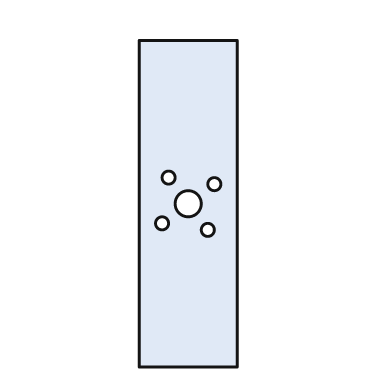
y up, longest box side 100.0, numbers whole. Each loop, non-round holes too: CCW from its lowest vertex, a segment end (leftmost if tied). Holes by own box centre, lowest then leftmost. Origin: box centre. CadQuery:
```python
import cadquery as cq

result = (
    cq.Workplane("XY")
    .moveTo(-15.0, -50.0)
    .lineTo(15.0, -50.0)
    .lineTo(15.0, 50.0)
    .lineTo(-15.0, 50.0)
    .close()
    .moveTo(6.0, -8.0)
    .circle(2.0)
    .moveTo(-8.0, -6.0)
    .circle(2.0)
    .moveTo(0.0, 0.0)
    .circle(4.0)
    .moveTo(8.0, 6.0)
    .circle(2.0)
    .moveTo(-6.0, 8.0)
    .circle(2.0)
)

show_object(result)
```